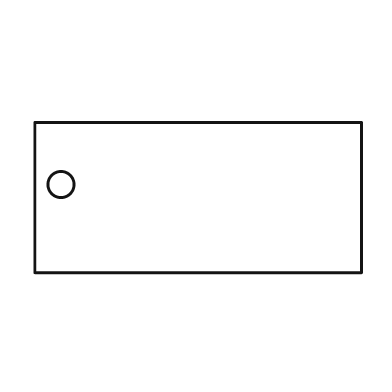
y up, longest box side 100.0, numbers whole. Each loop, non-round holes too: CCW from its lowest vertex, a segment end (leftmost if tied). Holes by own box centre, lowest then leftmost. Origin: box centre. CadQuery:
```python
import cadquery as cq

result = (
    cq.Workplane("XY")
    .moveTo(-50.0, -23.0)
    .lineTo(50.0, -23.0)
    .lineTo(50.0, 23.0)
    .lineTo(-50.0, 23.0)
    .close()
    .moveTo(-42.0, 4.0)
    .circle(4.0)
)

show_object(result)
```